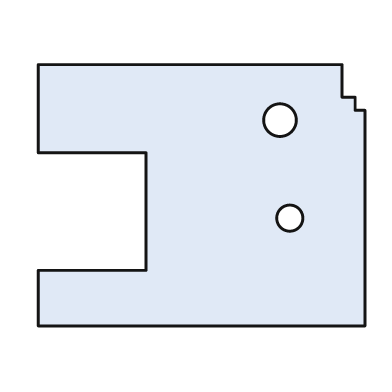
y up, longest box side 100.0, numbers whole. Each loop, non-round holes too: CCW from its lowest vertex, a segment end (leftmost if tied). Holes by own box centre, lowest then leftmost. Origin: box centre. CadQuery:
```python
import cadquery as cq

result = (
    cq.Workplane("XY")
    .moveTo(-50.0, -40.0)
    .lineTo(50.0, -40.0)
    .lineTo(50.0, 26.0)
    .lineTo(47.0, 26.0)
    .lineTo(47.0, 30.0)
    .lineTo(43.0, 30.0)
    .lineTo(43.0, 40.0)
    .lineTo(-50.0, 40.0)
    .lineTo(-50.0, 13.0)
    .lineTo(-17.0, 13.0)
    .lineTo(-17.0, -23.0)
    .lineTo(-50.0, -23.0)
    .close()
    .moveTo(27.0, -7.0)
    .circle(4.0)
    .moveTo(24.0, 23.0)
    .circle(5.0)
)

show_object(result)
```